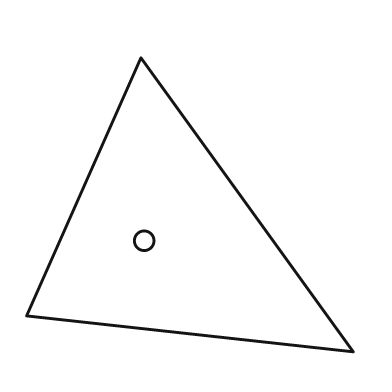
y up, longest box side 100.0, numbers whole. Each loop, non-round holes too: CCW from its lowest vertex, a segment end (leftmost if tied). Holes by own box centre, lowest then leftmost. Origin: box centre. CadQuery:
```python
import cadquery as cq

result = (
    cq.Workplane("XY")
    .moveTo(50.0, -45.0)
    .lineTo(-15.0, 45.0)
    .lineTo(-50.0, -34.0)
    .close()
    .moveTo(-14.0, -11.0)
    .circle(3.0)
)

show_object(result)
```